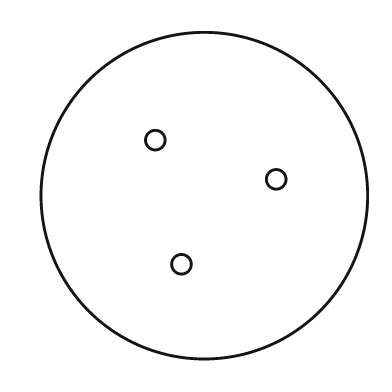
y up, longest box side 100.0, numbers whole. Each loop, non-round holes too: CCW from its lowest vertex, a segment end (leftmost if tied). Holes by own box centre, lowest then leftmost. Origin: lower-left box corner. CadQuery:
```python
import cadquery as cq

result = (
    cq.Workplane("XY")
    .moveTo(50.0, 50.0)
    .circle(50.0)
    .moveTo(43.0, 29.0)
    .circle(3.0)
    .moveTo(72.0, 55.0)
    .circle(3.0)
    .moveTo(35.0, 67.0)
    .circle(3.0)
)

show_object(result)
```